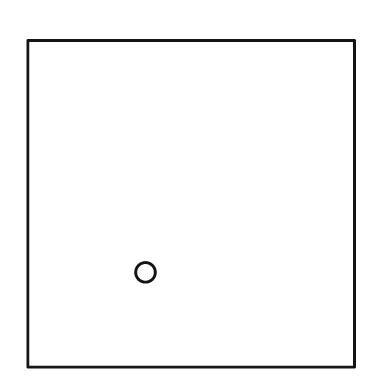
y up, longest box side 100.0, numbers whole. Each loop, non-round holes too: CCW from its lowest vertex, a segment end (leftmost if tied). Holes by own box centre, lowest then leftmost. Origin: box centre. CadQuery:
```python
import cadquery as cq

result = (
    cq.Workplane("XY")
    .moveTo(-50.0, -50.0)
    .lineTo(50.0, -50.0)
    .lineTo(50.0, 50.0)
    .lineTo(-50.0, 50.0)
    .close()
    .moveTo(-14.0, -21.0)
    .circle(3.0)
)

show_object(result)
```